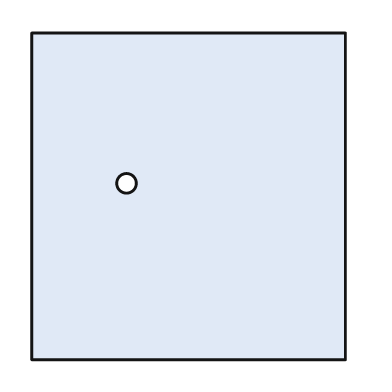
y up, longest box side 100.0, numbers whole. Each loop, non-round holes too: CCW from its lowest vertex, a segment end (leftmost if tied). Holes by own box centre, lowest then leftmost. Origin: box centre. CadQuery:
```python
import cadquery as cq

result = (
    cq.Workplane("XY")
    .moveTo(-48.0, -50.0)
    .lineTo(48.0, -50.0)
    .lineTo(48.0, 50.0)
    .lineTo(-48.0, 50.0)
    .close()
    .moveTo(-19.0, 4.0)
    .circle(3.0)
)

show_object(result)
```